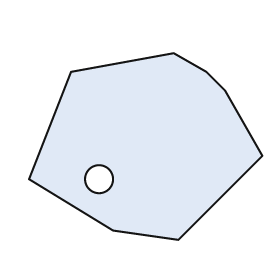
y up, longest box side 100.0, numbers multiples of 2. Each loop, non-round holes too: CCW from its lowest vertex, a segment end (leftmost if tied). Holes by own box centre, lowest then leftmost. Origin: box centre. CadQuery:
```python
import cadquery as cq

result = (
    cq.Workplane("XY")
    .moveTo(14.0, -40.0)
    .lineTo(50.0, -4.0)
    .lineTo(34.0, 24.0)
    .lineTo(26.0, 32.0)
    .lineTo(12.0, 40.0)
    .lineTo(-32.0, 32.0)
    .lineTo(-50.0, -14.0)
    .lineTo(-14.0, -36.0)
    .close()
    .moveTo(-20.0, -14.0)
    .circle(6.0)
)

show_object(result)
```